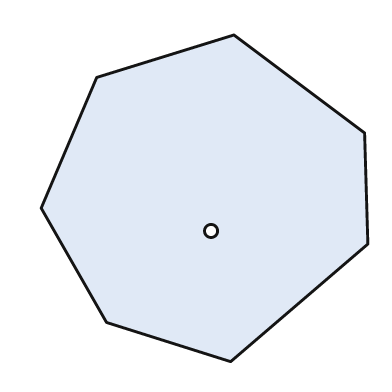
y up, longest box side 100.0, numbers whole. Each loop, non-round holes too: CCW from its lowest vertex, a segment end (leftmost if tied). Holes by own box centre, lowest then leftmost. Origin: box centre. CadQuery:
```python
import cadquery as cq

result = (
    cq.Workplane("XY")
    .moveTo(8.0, -50.0)
    .lineTo(50.0, -14.0)
    .lineTo(49.0, 20.0)
    .lineTo(9.0, 50.0)
    .lineTo(-33.0, 37.0)
    .lineTo(-50.0, -3.0)
    .lineTo(-30.0, -38.0)
    .close()
    .moveTo(2.0, -10.0)
    .circle(2.0)
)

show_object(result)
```